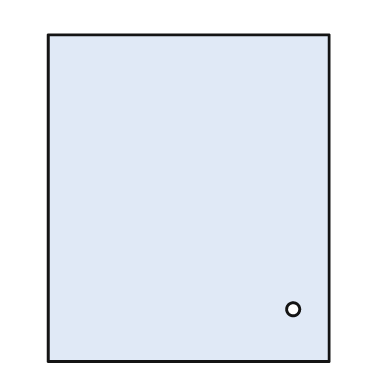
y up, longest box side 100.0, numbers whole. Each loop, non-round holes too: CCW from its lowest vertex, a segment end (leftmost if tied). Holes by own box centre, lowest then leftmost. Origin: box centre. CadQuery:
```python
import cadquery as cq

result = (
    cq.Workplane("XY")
    .moveTo(-43.0, -50.0)
    .lineTo(43.0, -50.0)
    .lineTo(43.0, 50.0)
    .lineTo(-43.0, 50.0)
    .close()
    .moveTo(32.0, -34.0)
    .circle(2.0)
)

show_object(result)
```